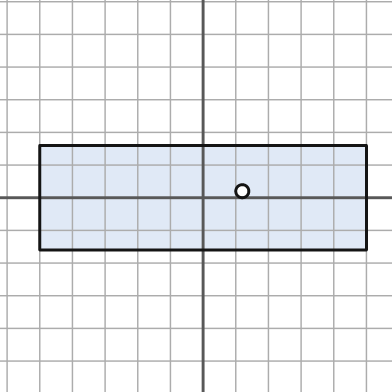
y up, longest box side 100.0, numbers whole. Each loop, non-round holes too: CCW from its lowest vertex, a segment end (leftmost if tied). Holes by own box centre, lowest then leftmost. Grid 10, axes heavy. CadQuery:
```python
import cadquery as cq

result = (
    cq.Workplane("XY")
    .moveTo(-50.0, -16.0)
    .lineTo(50.0, -16.0)
    .lineTo(50.0, 16.0)
    .lineTo(-50.0, 16.0)
    .close()
    .moveTo(12.0, 2.0)
    .circle(2.0)
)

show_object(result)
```